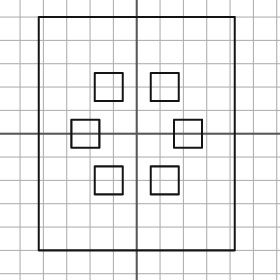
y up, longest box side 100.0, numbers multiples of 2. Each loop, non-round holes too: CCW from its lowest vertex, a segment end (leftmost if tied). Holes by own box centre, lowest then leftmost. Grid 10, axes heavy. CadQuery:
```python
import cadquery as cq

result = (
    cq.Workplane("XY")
    .moveTo(-42.0, -50.0)
    .lineTo(42.0, -50.0)
    .lineTo(42.0, 50.0)
    .lineTo(-42.0, 50.0)
    .close()
    .moveTo(-18.0, -26.0)
    .lineTo(-6.0, -26.0)
    .lineTo(-6.0, -14.0)
    .lineTo(-18.0, -14.0)
    .close()
    .moveTo(6.0, -26.0)
    .lineTo(18.0, -26.0)
    .lineTo(18.0, -14.0)
    .lineTo(6.0, -14.0)
    .close()
    .moveTo(-28.0, -6.0)
    .lineTo(-16.0, -6.0)
    .lineTo(-16.0, 6.0)
    .lineTo(-28.0, 6.0)
    .close()
    .moveTo(16.0, -6.0)
    .lineTo(28.0, -6.0)
    .lineTo(28.0, 6.0)
    .lineTo(16.0, 6.0)
    .close()
    .moveTo(-18.0, 14.0)
    .lineTo(-6.0, 14.0)
    .lineTo(-6.0, 26.0)
    .lineTo(-18.0, 26.0)
    .close()
    .moveTo(6.0, 14.0)
    .lineTo(18.0, 14.0)
    .lineTo(18.0, 26.0)
    .lineTo(6.0, 26.0)
    .close()
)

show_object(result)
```